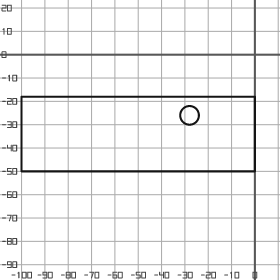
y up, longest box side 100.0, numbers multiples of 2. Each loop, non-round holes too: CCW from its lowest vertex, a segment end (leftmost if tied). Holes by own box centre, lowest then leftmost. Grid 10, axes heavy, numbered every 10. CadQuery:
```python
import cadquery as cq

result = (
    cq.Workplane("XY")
    .moveTo(-100.0, -50.0)
    .lineTo(0.0, -50.0)
    .lineTo(0.0, -18.0)
    .lineTo(-100.0, -18.0)
    .close()
    .moveTo(-28.0, -26.0)
    .circle(4.0)
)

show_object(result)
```